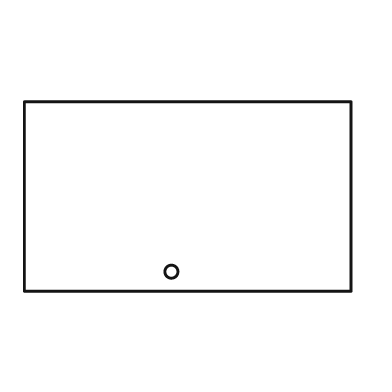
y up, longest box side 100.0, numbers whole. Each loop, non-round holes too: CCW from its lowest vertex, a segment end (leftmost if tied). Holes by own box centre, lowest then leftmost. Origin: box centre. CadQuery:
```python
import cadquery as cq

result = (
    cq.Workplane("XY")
    .moveTo(-50.0, -29.0)
    .lineTo(50.0, -29.0)
    .lineTo(50.0, 29.0)
    .lineTo(-50.0, 29.0)
    .close()
    .moveTo(-5.0, -23.0)
    .circle(2.0)
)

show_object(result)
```